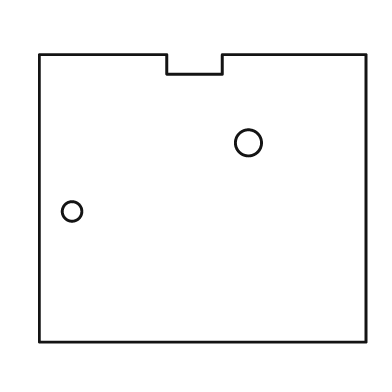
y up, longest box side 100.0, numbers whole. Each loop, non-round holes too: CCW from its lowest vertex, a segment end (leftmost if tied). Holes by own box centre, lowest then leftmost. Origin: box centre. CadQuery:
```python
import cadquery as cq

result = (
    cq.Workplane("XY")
    .moveTo(-50.0, -44.0)
    .lineTo(50.0, -44.0)
    .lineTo(50.0, 44.0)
    .lineTo(6.0, 44.0)
    .lineTo(6.0, 38.0)
    .lineTo(-11.0, 38.0)
    .lineTo(-11.0, 44.0)
    .lineTo(-50.0, 44.0)
    .close()
    .moveTo(-40.0, -4.0)
    .circle(3.0)
    .moveTo(14.0, 17.0)
    .circle(4.0)
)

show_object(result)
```